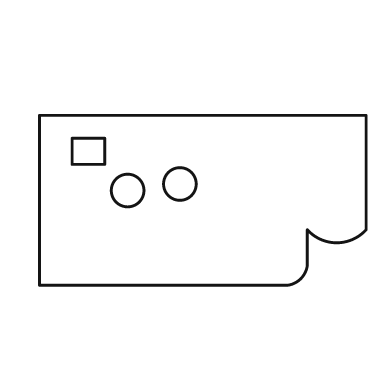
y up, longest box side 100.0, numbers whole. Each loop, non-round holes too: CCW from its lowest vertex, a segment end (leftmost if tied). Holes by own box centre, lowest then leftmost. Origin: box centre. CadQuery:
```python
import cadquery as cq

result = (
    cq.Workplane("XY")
    .moveTo(-50.0, -26.0)
    .lineTo(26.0, -26.0)
    .threePointArc((30.0, -24.0), (32.0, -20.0))
    .lineTo(32.0, -9.0)
    .threePointArc((41.0, -13.0), (50.0, -9.0))
    .lineTo(50.0, 26.0)
    .lineTo(-50.0, 26.0)
    .close()
    .moveTo(-23.0, 3.0)
    .circle(5.0)
    .moveTo(-7.0, 5.0)
    .circle(5.0)
    .moveTo(-40.0, 11.0)
    .lineTo(-30.0, 11.0)
    .lineTo(-30.0, 19.0)
    .lineTo(-40.0, 19.0)
    .close()
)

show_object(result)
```